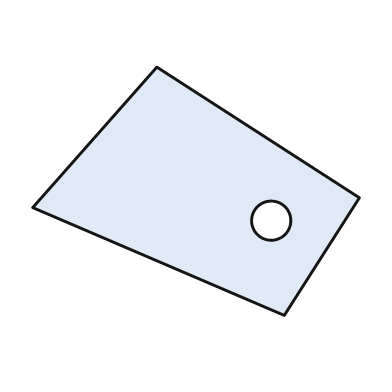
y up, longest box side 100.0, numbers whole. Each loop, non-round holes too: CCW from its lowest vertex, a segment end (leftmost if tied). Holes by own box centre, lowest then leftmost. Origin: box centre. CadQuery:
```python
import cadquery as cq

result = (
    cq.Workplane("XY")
    .moveTo(27.0, -38.0)
    .lineTo(50.0, -2.0)
    .lineTo(-12.0, 38.0)
    .lineTo(-50.0, -5.0)
    .close()
    .moveTo(23.0, -9.0)
    .circle(6.0)
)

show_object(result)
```